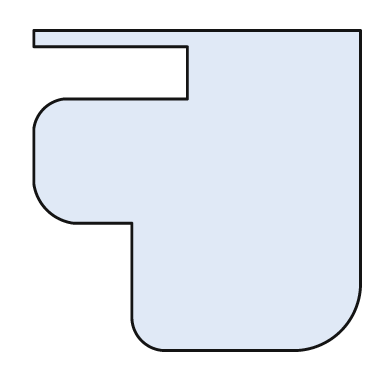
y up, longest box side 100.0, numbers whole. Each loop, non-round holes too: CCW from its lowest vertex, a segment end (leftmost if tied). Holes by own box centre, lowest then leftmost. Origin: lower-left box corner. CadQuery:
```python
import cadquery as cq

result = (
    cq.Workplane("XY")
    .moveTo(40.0, 0.0)
    .lineTo(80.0, 0.0)
    .threePointArc((94.0, 6.0), (100.0, 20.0))
    .lineTo(100.0, 98.0)
    .lineTo(0.0, 98.0)
    .lineTo(0.0, 93.0)
    .lineTo(47.0, 93.0)
    .lineTo(47.0, 77.0)
    .lineTo(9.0, 77.0)
    .threePointArc((3.0, 74.0), (0.0, 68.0))
    .lineTo(0.0, 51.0)
    .threePointArc((4.0, 43.0), (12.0, 39.0))
    .lineTo(30.0, 39.0)
    .lineTo(30.0, 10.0)
    .threePointArc((33.0, 3.0), (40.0, 0.0))
    .close()
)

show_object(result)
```